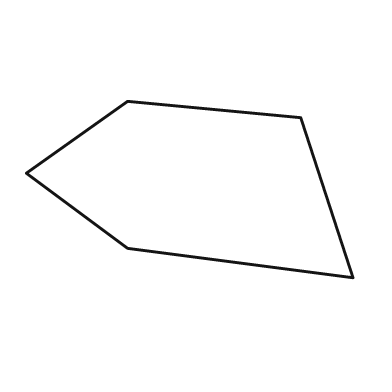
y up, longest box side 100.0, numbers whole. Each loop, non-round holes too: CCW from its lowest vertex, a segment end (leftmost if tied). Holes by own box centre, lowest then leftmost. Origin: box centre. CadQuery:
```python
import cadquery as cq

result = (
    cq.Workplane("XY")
    .moveTo(50.0, -27.0)
    .lineTo(34.0, 22.0)
    .lineTo(-19.0, 27.0)
    .lineTo(-50.0, 5.0)
    .lineTo(-19.0, -18.0)
    .close()
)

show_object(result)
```